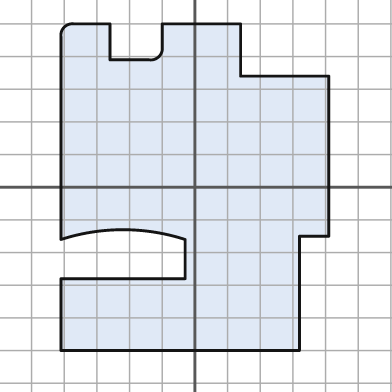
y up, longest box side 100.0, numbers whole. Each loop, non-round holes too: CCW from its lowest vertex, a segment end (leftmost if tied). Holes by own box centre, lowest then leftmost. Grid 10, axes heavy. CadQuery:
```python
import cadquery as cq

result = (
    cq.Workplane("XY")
    .moveTo(-41.0, -50.0)
    .lineTo(32.0, -50.0)
    .lineTo(32.0, -15.0)
    .lineTo(41.0, -15.0)
    .lineTo(41.0, 34.0)
    .lineTo(14.0, 34.0)
    .lineTo(14.0, 50.0)
    .lineTo(-10.0, 50.0)
    .lineTo(-10.0, 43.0)
    .threePointArc((-11.0, 40.0), (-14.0, 39.0))
    .lineTo(-26.0, 39.0)
    .lineTo(-26.0, 50.0)
    .lineTo(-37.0, 50.0)
    .threePointArc((-40.0, 49.0), (-41.0, 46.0))
    .lineTo(-41.0, -16.0)
    .threePointArc((-22.0, -13.0), (-3.0, -16.0))
    .lineTo(-3.0, -28.0)
    .lineTo(-41.0, -28.0)
    .close()
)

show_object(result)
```